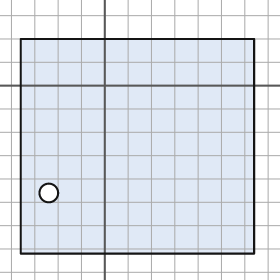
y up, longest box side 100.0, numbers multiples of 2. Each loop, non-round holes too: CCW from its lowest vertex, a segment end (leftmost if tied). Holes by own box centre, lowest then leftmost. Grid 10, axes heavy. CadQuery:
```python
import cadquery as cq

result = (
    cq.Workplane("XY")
    .moveTo(-36.0, -72.0)
    .lineTo(64.0, -72.0)
    .lineTo(64.0, 20.0)
    .lineTo(-36.0, 20.0)
    .close()
    .moveTo(-24.0, -46.0)
    .circle(4.0)
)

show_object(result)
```